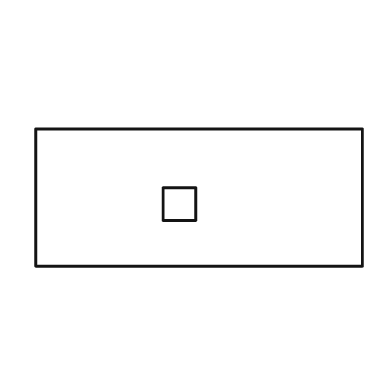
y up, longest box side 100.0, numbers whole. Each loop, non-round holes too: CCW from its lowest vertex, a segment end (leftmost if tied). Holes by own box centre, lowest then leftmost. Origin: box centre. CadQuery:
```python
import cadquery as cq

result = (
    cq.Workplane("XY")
    .moveTo(-50.0, -21.0)
    .lineTo(50.0, -21.0)
    .lineTo(50.0, 21.0)
    .lineTo(-50.0, 21.0)
    .close()
    .moveTo(-11.0, -7.0)
    .lineTo(-1.0, -7.0)
    .lineTo(-1.0, 3.0)
    .lineTo(-11.0, 3.0)
    .close()
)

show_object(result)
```